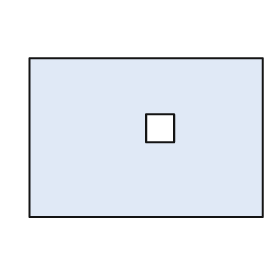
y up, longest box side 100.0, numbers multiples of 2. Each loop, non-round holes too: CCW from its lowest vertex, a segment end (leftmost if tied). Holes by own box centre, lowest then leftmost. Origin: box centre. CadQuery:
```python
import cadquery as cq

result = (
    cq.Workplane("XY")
    .moveTo(-50.0, -34.0)
    .lineTo(50.0, -34.0)
    .lineTo(50.0, 34.0)
    .lineTo(-50.0, 34.0)
    .close()
    .moveTo(0.0, -2.0)
    .lineTo(12.0, -2.0)
    .lineTo(12.0, 10.0)
    .lineTo(0.0, 10.0)
    .close()
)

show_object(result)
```